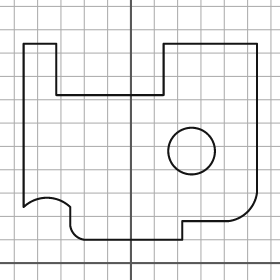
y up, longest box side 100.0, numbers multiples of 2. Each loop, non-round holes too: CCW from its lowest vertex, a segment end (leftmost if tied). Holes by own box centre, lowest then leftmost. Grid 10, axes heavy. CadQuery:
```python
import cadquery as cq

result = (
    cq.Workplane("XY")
    .moveTo(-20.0, 10.0)
    .lineTo(22.0, 10.0)
    .lineTo(22.0, 18.0)
    .lineTo(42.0, 18.0)
    .threePointArc((50.0, 22.0), (54.0, 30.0))
    .lineTo(54.0, 94.0)
    .lineTo(14.0, 94.0)
    .lineTo(14.0, 72.0)
    .lineTo(-32.0, 72.0)
    .lineTo(-32.0, 94.0)
    .lineTo(-46.0, 94.0)
    .lineTo(-46.0, 24.0)
    .threePointArc((-36.0, 28.0), (-26.0, 24.0))
    .lineTo(-26.0, 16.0)
    .threePointArc((-24.0, 12.0), (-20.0, 10.0))
    .close()
    .moveTo(26.0, 48.0)
    .circle(10.0)
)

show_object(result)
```